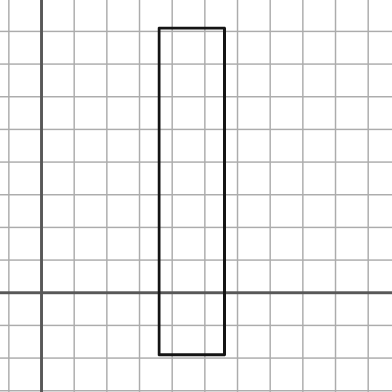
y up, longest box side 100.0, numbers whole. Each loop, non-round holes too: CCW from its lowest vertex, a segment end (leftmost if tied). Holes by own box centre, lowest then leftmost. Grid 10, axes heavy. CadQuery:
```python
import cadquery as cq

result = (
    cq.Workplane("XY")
    .moveTo(36.0, -19.0)
    .lineTo(56.0, -19.0)
    .lineTo(56.0, 81.0)
    .lineTo(36.0, 81.0)
    .close()
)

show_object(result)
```